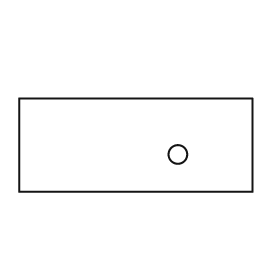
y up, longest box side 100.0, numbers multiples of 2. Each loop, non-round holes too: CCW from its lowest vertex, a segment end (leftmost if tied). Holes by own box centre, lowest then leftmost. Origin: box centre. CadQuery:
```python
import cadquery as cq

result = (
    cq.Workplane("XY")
    .moveTo(-50.0, -20.0)
    .lineTo(50.0, -20.0)
    .lineTo(50.0, 20.0)
    .lineTo(-50.0, 20.0)
    .close()
    .moveTo(18.0, -4.0)
    .circle(4.0)
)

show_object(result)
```